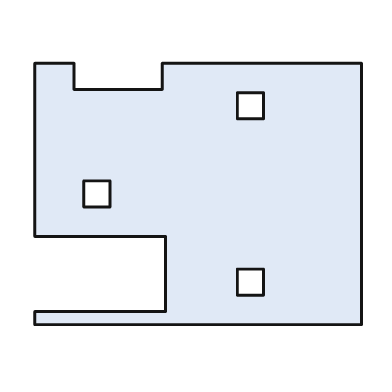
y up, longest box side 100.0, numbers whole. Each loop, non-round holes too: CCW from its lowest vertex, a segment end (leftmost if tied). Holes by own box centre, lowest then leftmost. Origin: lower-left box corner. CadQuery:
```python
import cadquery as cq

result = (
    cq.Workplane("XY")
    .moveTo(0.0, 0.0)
    .lineTo(100.0, 0.0)
    .lineTo(100.0, 80.0)
    .lineTo(39.0, 80.0)
    .lineTo(39.0, 72.0)
    .lineTo(12.0, 72.0)
    .lineTo(12.0, 80.0)
    .lineTo(0.0, 80.0)
    .lineTo(0.0, 27.0)
    .lineTo(40.0, 27.0)
    .lineTo(40.0, 4.0)
    .lineTo(0.0, 4.0)
    .close()
    .moveTo(62.0, 9.0)
    .lineTo(70.0, 9.0)
    .lineTo(70.0, 17.0)
    .lineTo(62.0, 17.0)
    .close()
    .moveTo(15.0, 36.0)
    .lineTo(23.0, 36.0)
    .lineTo(23.0, 44.0)
    .lineTo(15.0, 44.0)
    .close()
    .moveTo(62.0, 63.0)
    .lineTo(70.0, 63.0)
    .lineTo(70.0, 71.0)
    .lineTo(62.0, 71.0)
    .close()
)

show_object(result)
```